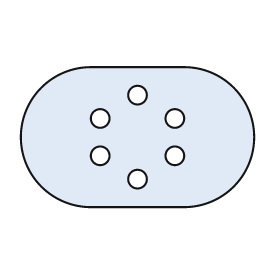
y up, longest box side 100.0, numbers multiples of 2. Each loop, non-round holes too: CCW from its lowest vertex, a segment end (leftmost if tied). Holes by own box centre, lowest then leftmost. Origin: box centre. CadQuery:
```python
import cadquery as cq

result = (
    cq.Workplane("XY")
    .moveTo(-20.0, -30.0)
    .lineTo(20.0, -30.0)
    .threePointArc((50.0, 0.0), (20.0, 30.0))
    .lineTo(-20.0, 30.0)
    .threePointArc((-50.0, 0.0), (-20.0, -30.0))
    .close()
    .moveTo(0.0, -18.0)
    .circle(4.0)
    .moveTo(-16.0, -8.0)
    .circle(4.0)
    .moveTo(16.0, -8.0)
    .circle(4.0)
    .moveTo(-16.0, 8.0)
    .circle(4.0)
    .moveTo(16.0, 8.0)
    .circle(4.0)
    .moveTo(0.0, 18.0)
    .circle(4.0)
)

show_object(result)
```